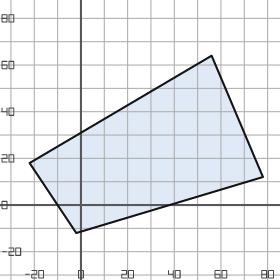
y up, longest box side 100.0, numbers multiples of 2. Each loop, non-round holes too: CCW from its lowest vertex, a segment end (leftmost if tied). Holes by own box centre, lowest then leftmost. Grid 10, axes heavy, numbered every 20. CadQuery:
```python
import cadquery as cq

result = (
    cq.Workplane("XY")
    .moveTo(-2.0, -12.0)
    .lineTo(78.0, 12.0)
    .lineTo(56.0, 64.0)
    .lineTo(-22.0, 18.0)
    .close()
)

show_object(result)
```